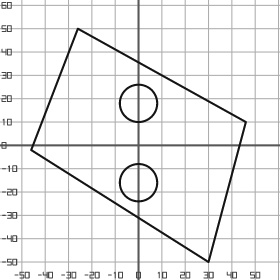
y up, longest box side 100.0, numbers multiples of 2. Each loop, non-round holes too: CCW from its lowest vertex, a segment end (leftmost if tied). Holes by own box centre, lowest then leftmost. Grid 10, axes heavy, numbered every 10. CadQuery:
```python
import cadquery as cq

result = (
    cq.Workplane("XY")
    .moveTo(30.0, -50.0)
    .lineTo(46.0, 10.0)
    .lineTo(-26.0, 50.0)
    .lineTo(-46.0, -2.0)
    .close()
    .moveTo(0.0, -16.0)
    .circle(8.0)
    .moveTo(0.0, 18.0)
    .circle(8.0)
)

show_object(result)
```